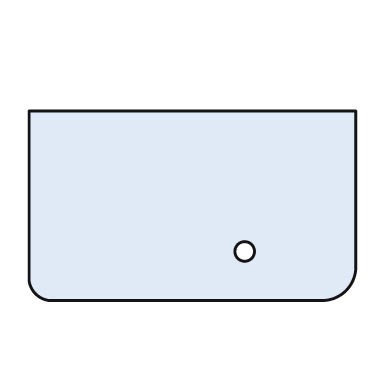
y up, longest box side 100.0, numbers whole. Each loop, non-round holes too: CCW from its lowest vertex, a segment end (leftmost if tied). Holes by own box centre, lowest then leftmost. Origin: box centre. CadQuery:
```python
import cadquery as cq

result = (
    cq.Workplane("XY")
    .moveTo(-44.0, -29.0)
    .lineTo(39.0, -29.0)
    .threePointArc((47.0, -26.0), (50.0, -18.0))
    .lineTo(50.0, 29.0)
    .lineTo(-50.0, 29.0)
    .lineTo(-50.0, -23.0)
    .threePointArc((-48.0, -27.0), (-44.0, -29.0))
    .close()
    .moveTo(16.0, -14.0)
    .circle(3.0)
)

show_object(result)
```